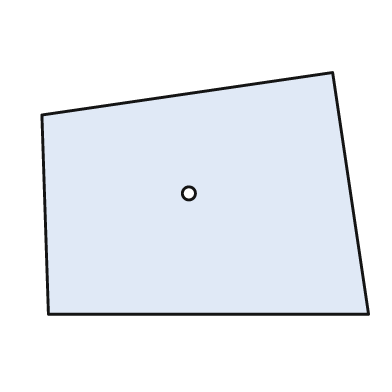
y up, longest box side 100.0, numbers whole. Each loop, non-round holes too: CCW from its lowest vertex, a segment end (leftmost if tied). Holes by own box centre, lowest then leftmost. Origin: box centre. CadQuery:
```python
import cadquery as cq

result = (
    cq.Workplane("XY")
    .moveTo(-48.0, -37.0)
    .lineTo(50.0, -37.0)
    .lineTo(39.0, 37.0)
    .lineTo(-50.0, 24.0)
    .close()
    .moveTo(-5.0, 0.0)
    .circle(2.0)
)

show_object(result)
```